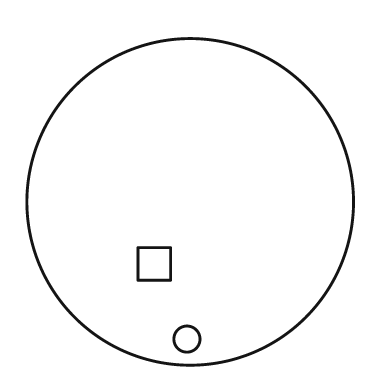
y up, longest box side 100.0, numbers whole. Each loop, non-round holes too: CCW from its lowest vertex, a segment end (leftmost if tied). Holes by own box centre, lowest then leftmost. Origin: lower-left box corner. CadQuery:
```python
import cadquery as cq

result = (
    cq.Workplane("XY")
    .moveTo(50.0, 50.0)
    .circle(50.0)
    .moveTo(49.0, 8.0)
    .circle(4.0)
    .moveTo(34.0, 26.0)
    .lineTo(44.0, 26.0)
    .lineTo(44.0, 36.0)
    .lineTo(34.0, 36.0)
    .close()
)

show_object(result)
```